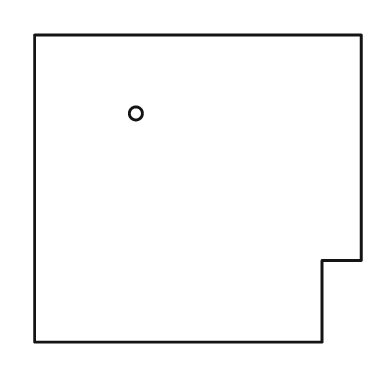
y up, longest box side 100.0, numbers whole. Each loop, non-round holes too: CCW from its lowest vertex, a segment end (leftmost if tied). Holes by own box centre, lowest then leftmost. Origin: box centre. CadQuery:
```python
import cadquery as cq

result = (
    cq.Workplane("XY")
    .moveTo(-50.0, -47.0)
    .lineTo(38.0, -47.0)
    .lineTo(38.0, -22.0)
    .lineTo(50.0, -22.0)
    .lineTo(50.0, 47.0)
    .lineTo(-50.0, 47.0)
    .close()
    .moveTo(-19.0, 23.0)
    .circle(2.0)
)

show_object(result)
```